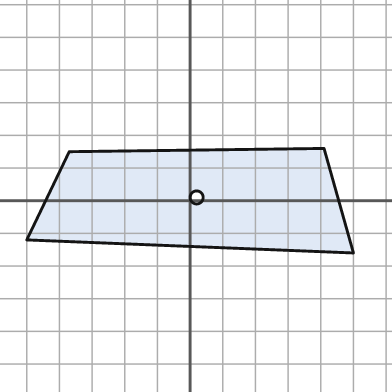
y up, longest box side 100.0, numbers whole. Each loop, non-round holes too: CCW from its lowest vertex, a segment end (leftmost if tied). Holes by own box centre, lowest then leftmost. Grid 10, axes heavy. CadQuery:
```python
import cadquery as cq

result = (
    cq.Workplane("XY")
    .moveTo(50.0, -16.0)
    .lineTo(41.0, 16.0)
    .lineTo(-37.0, 15.0)
    .lineTo(-50.0, -12.0)
    .close()
    .moveTo(2.0, 1.0)
    .circle(2.0)
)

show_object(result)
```